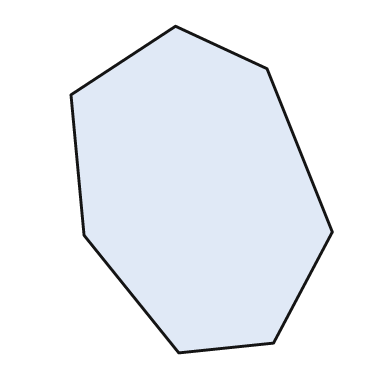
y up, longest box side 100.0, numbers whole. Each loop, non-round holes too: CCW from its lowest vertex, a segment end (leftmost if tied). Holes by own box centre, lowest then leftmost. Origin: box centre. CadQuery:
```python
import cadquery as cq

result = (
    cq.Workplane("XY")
    .moveTo(-7.0, -50.0)
    .lineTo(22.0, -47.0)
    .lineTo(40.0, -13.0)
    .lineTo(20.0, 37.0)
    .lineTo(-8.0, 50.0)
    .lineTo(-40.0, 29.0)
    .lineTo(-36.0, -14.0)
    .close()
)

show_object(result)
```